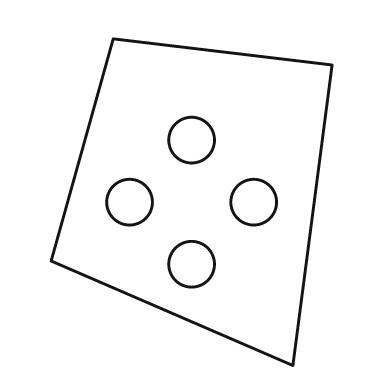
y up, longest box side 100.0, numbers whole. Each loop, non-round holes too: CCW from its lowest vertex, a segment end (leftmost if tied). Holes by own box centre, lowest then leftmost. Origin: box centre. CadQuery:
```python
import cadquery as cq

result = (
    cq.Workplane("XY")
    .moveTo(31.0, -50.0)
    .lineTo(43.0, 42.0)
    .lineTo(-24.0, 50.0)
    .lineTo(-43.0, -18.0)
    .close()
    .moveTo(0.0, -19.0)
    .circle(7.0)
    .moveTo(-19.0, 0.0)
    .circle(7.0)
    .moveTo(19.0, 0.0)
    .circle(7.0)
    .moveTo(0.0, 19.0)
    .circle(7.0)
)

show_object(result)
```